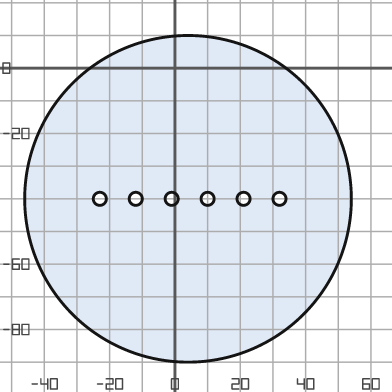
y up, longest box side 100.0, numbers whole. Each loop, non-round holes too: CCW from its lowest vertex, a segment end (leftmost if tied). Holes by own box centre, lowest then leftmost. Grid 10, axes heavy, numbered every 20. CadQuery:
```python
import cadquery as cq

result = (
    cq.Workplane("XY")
    .moveTo(4.0, -40.0)
    .circle(50.0)
    .moveTo(-23.0, -40.0)
    .circle(2.0)
    .moveTo(-12.0, -40.0)
    .circle(2.0)
    .moveTo(-1.0, -40.0)
    .circle(2.0)
    .moveTo(10.0, -40.0)
    .circle(2.0)
    .moveTo(21.0, -40.0)
    .circle(2.0)
    .moveTo(32.0, -40.0)
    .circle(2.0)
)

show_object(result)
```